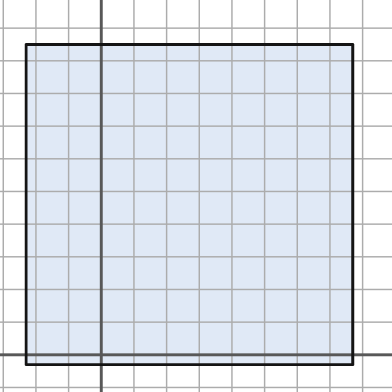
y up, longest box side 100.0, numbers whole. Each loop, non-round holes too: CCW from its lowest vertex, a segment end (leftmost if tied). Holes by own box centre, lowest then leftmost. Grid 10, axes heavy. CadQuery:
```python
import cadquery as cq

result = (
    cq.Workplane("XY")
    .moveTo(-23.0, -3.0)
    .lineTo(77.0, -3.0)
    .lineTo(77.0, 95.0)
    .lineTo(-23.0, 95.0)
    .close()
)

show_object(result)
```